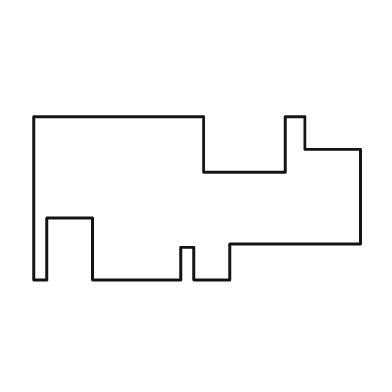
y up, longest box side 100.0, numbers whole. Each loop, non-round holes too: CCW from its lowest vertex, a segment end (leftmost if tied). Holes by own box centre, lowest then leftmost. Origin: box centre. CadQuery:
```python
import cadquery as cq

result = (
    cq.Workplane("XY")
    .moveTo(-50.0, -25.0)
    .lineTo(-46.0, -25.0)
    .lineTo(-46.0, -6.0)
    .lineTo(-32.0, -6.0)
    .lineTo(-32.0, -25.0)
    .lineTo(-5.0, -25.0)
    .lineTo(-5.0, -15.0)
    .lineTo(-1.0, -15.0)
    .lineTo(-1.0, -25.0)
    .lineTo(10.0, -25.0)
    .lineTo(10.0, -14.0)
    .lineTo(50.0, -14.0)
    .lineTo(50.0, 15.0)
    .lineTo(33.0, 15.0)
    .lineTo(33.0, 25.0)
    .lineTo(27.0, 25.0)
    .lineTo(27.0, 8.0)
    .lineTo(2.0, 8.0)
    .lineTo(2.0, 25.0)
    .lineTo(-50.0, 25.0)
    .close()
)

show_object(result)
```